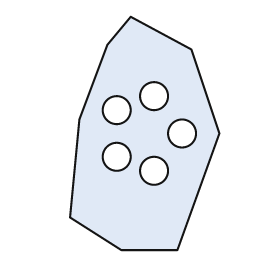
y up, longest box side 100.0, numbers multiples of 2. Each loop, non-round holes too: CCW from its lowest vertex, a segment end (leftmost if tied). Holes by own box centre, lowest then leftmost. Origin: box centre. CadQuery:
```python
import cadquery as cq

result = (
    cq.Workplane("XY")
    .moveTo(-10.0, -50.0)
    .lineTo(14.0, -50.0)
    .lineTo(32.0, 0.0)
    .lineTo(20.0, 36.0)
    .lineTo(-6.0, 50.0)
    .lineTo(-16.0, 38.0)
    .lineTo(-28.0, 6.0)
    .lineTo(-32.0, -36.0)
    .close()
    .moveTo(4.0, -16.0)
    .circle(6.0)
    .moveTo(-12.0, -10.0)
    .circle(6.0)
    .moveTo(16.0, 0.0)
    .circle(6.0)
    .moveTo(-12.0, 10.0)
    .circle(6.0)
    .moveTo(4.0, 16.0)
    .circle(6.0)
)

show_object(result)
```